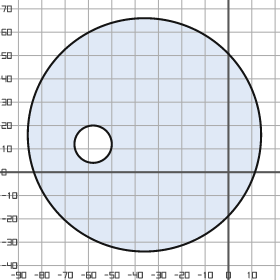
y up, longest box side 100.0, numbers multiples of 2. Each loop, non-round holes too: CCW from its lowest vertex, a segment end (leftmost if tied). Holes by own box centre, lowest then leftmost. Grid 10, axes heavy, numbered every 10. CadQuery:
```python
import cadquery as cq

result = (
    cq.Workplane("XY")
    .moveTo(-36.0, 16.0)
    .circle(50.0)
    .moveTo(-58.0, 12.0)
    .circle(8.0)
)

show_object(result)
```